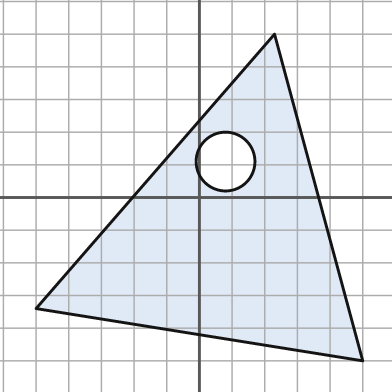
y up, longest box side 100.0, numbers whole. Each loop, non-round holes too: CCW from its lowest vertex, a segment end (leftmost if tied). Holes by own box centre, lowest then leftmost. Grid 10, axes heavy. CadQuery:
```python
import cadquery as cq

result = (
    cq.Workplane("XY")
    .moveTo(50.0, -50.0)
    .lineTo(23.0, 50.0)
    .lineTo(-50.0, -34.0)
    .close()
    .moveTo(8.0, 11.0)
    .circle(9.0)
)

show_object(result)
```